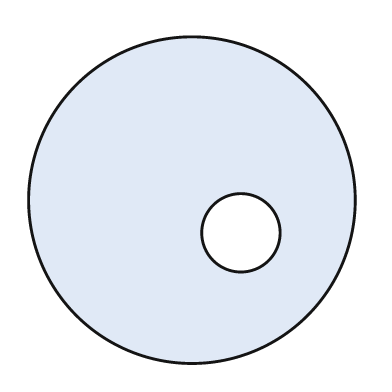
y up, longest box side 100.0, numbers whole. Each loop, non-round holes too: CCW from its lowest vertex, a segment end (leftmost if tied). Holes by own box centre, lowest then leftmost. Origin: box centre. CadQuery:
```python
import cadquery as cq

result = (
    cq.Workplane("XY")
    .moveTo(0.0, 0.0)
    .circle(50.0)
    .moveTo(15.0, -10.0)
    .circle(12.0)
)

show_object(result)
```